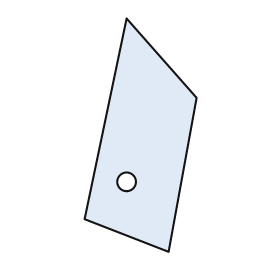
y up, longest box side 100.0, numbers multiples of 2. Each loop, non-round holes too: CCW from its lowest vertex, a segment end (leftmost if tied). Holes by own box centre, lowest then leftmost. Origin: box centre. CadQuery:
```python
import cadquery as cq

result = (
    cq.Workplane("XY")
    .moveTo(12.0, -50.0)
    .lineTo(24.0, 16.0)
    .lineTo(-6.0, 50.0)
    .lineTo(-24.0, -36.0)
    .close()
    .moveTo(-6.0, -20.0)
    .circle(4.0)
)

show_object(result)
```